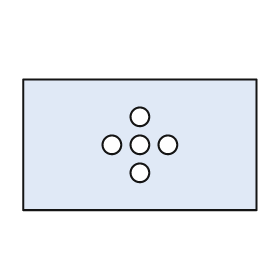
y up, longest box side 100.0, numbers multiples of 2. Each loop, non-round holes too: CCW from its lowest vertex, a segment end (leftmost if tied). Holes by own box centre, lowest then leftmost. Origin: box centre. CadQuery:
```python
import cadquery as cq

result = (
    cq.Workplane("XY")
    .moveTo(-50.0, -28.0)
    .lineTo(50.0, -28.0)
    .lineTo(50.0, 28.0)
    .lineTo(-50.0, 28.0)
    .close()
    .moveTo(0.0, -12.0)
    .circle(4.0)
    .moveTo(-12.0, 0.0)
    .circle(4.0)
    .moveTo(0.0, 0.0)
    .circle(4.0)
    .moveTo(12.0, 0.0)
    .circle(4.0)
    .moveTo(0.0, 12.0)
    .circle(4.0)
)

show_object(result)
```